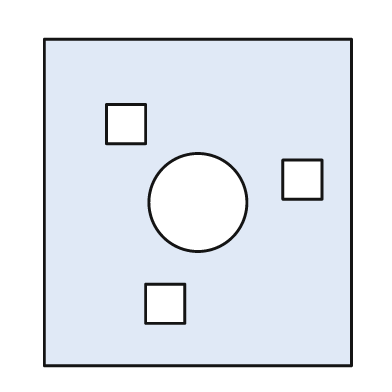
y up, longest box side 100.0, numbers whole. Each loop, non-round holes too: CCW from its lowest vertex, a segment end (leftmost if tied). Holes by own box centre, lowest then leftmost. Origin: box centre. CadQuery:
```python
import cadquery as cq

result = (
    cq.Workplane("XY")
    .moveTo(-47.0, -50.0)
    .lineTo(47.0, -50.0)
    .lineTo(47.0, 50.0)
    .lineTo(-47.0, 50.0)
    .close()
    .moveTo(-16.0, -37.0)
    .lineTo(-4.0, -37.0)
    .lineTo(-4.0, -25.0)
    .lineTo(-16.0, -25.0)
    .close()
    .moveTo(0.0, 0.0)
    .circle(15.0)
    .moveTo(26.0, 1.0)
    .lineTo(38.0, 1.0)
    .lineTo(38.0, 13.0)
    .lineTo(26.0, 13.0)
    .close()
    .moveTo(-28.0, 18.0)
    .lineTo(-16.0, 18.0)
    .lineTo(-16.0, 30.0)
    .lineTo(-28.0, 30.0)
    .close()
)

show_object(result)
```